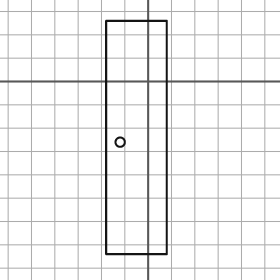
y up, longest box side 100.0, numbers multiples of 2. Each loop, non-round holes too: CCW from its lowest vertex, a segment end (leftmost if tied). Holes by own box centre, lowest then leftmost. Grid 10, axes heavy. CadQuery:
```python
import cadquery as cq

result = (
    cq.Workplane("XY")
    .moveTo(-18.0, -74.0)
    .lineTo(8.0, -74.0)
    .lineTo(8.0, 26.0)
    .lineTo(-18.0, 26.0)
    .close()
    .moveTo(-12.0, -26.0)
    .circle(2.0)
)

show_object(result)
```